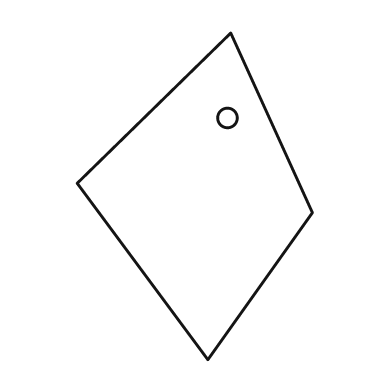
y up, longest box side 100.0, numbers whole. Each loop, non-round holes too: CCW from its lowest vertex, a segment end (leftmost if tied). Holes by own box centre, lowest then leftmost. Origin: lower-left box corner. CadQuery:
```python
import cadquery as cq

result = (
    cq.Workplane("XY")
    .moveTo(40.0, 0.0)
    .lineTo(72.0, 45.0)
    .lineTo(47.0, 100.0)
    .lineTo(0.0, 54.0)
    .close()
    .moveTo(46.0, 74.0)
    .circle(3.0)
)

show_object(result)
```